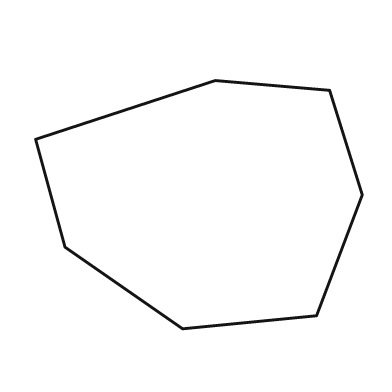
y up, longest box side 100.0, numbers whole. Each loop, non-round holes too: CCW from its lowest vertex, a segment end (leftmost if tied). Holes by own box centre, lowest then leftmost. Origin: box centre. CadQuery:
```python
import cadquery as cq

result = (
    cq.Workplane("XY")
    .moveTo(-5.0, -38.0)
    .lineTo(36.0, -34.0)
    .lineTo(50.0, 3.0)
    .lineTo(40.0, 35.0)
    .lineTo(5.0, 38.0)
    .lineTo(-50.0, 20.0)
    .lineTo(-41.0, -13.0)
    .close()
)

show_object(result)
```